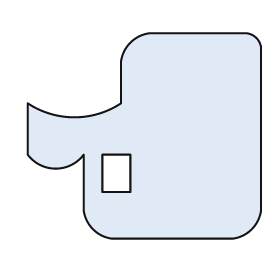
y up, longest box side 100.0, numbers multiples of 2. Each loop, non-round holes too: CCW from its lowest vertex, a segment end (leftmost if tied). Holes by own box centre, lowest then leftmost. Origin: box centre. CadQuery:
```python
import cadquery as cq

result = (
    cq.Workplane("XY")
    .moveTo(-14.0, -44.0)
    .lineTo(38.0, -44.0)
    .threePointArc((46.0, -40.0), (50.0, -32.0))
    .lineTo(50.0, 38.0)
    .threePointArc((48.0, 42.0), (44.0, 44.0))
    .lineTo(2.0, 44.0)
    .threePointArc((-6.0, 40.0), (-10.0, 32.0))
    .lineTo(-10.0, 14.0)
    .threePointArc((-30.0, 8.0), (-50.0, 14.0))
    .lineTo(-50.0, -8.0)
    .threePointArc((-38.0, -14.0), (-26.0, -8.0))
    .lineTo(-26.0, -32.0)
    .threePointArc((-22.0, -40.0), (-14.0, -44.0))
    .close()
    .moveTo(-18.0, -24.0)
    .lineTo(-6.0, -24.0)
    .lineTo(-6.0, -8.0)
    .lineTo(-18.0, -8.0)
    .close()
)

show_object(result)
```